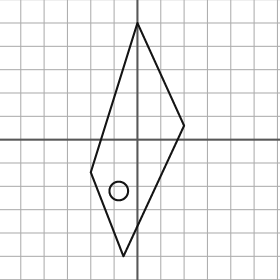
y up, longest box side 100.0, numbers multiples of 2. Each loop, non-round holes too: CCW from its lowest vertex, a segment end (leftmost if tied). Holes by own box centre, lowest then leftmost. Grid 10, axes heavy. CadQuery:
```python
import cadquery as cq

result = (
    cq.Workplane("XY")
    .moveTo(-6.0, -50.0)
    .lineTo(20.0, 6.0)
    .lineTo(0.0, 50.0)
    .lineTo(-20.0, -14.0)
    .close()
    .moveTo(-8.0, -22.0)
    .circle(4.0)
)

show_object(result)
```